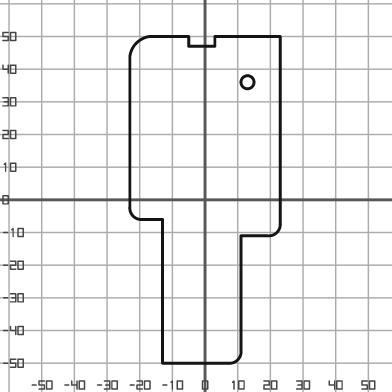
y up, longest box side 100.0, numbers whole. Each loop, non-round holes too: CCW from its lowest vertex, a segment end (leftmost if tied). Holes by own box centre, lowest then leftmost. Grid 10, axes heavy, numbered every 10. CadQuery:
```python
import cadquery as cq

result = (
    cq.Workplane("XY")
    .moveTo(-13.0, -50.0)
    .lineTo(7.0, -50.0)
    .threePointArc((10.0, -49.0), (11.0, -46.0))
    .lineTo(11.0, -11.0)
    .lineTo(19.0, -11.0)
    .threePointArc((22.0, -10.0), (23.0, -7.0))
    .lineTo(23.0, 50.0)
    .lineTo(3.0, 50.0)
    .lineTo(3.0, 47.0)
    .lineTo(-5.0, 47.0)
    .lineTo(-5.0, 50.0)
    .lineTo(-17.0, 50.0)
    .threePointArc((-21.0, 48.0), (-23.0, 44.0))
    .lineTo(-23.0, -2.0)
    .threePointArc((-22.0, -5.0), (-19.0, -6.0))
    .lineTo(-13.0, -6.0)
    .close()
    .moveTo(13.0, 36.0)
    .circle(2.0)
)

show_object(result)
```